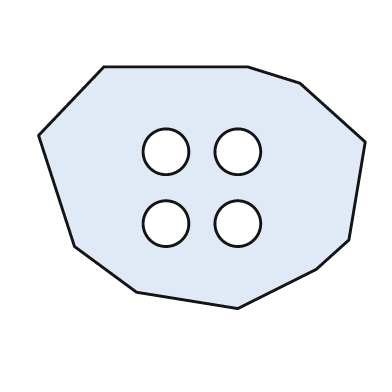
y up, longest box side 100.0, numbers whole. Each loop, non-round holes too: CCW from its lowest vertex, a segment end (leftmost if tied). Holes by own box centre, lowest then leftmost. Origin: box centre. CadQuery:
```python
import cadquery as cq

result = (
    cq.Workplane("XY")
    .moveTo(11.0, -37.0)
    .lineTo(35.0, -25.0)
    .lineTo(45.0, -16.0)
    .lineTo(50.0, 14.0)
    .lineTo(30.0, 32.0)
    .lineTo(14.0, 37.0)
    .lineTo(-30.0, 37.0)
    .lineTo(-50.0, 16.0)
    .lineTo(-39.0, -18.0)
    .lineTo(-20.0, -32.0)
    .close()
    .moveTo(-11.0, -11.0)
    .circle(7.0)
    .moveTo(11.0, -11.0)
    .circle(7.0)
    .moveTo(-11.0, 11.0)
    .circle(7.0)
    .moveTo(11.0, 11.0)
    .circle(7.0)
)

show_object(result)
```